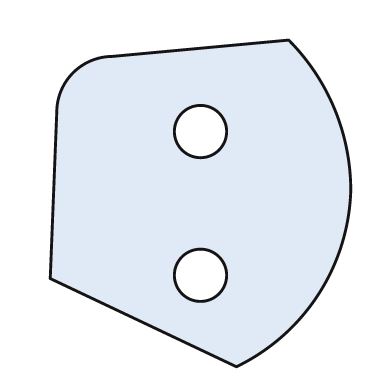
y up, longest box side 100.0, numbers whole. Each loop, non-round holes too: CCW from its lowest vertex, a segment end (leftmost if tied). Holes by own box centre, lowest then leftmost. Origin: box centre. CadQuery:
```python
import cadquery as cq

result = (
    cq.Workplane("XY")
    .moveTo(11.0, -50.0)
    .threePointArc((36.0, -28.0), (46.0, 4.0))
    .threePointArc((41.0, 29.0), (27.0, 50.0))
    .lineTo(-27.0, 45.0)
    .threePointArc((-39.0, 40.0), (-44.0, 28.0))
    .lineTo(-46.0, -23.0)
    .close()
    .moveTo(0.0, -22.0)
    .circle(8.0)
    .moveTo(0.0, 22.0)
    .circle(8.0)
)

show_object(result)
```